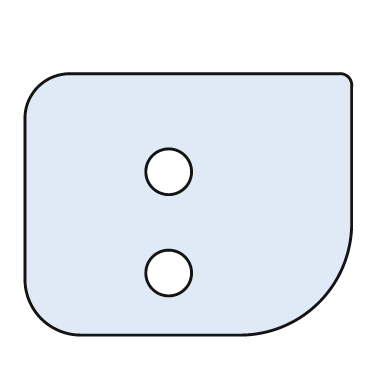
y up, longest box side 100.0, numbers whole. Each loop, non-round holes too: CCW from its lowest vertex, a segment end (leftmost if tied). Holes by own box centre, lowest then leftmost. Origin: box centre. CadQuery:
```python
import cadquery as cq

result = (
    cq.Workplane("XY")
    .moveTo(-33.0, -40.0)
    .lineTo(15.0, -40.0)
    .threePointArc((40.0, -30.0), (50.0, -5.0))
    .lineTo(50.0, 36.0)
    .threePointArc((49.0, 39.0), (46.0, 40.0))
    .lineTo(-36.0, 40.0)
    .threePointArc((-46.0, 36.0), (-50.0, 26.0))
    .lineTo(-50.0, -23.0)
    .threePointArc((-45.0, -35.0), (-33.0, -40.0))
    .close()
    .moveTo(-6.0, -21.0)
    .circle(7.0)
    .moveTo(-6.0, 10.0)
    .circle(7.0)
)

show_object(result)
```